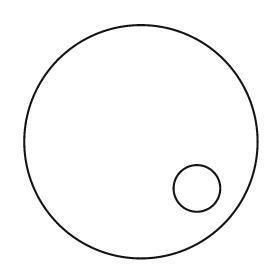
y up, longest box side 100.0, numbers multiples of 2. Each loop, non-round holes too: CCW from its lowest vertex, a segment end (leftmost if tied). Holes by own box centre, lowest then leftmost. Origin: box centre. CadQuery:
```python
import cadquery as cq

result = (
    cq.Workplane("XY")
    .moveTo(0.0, 0.0)
    .circle(50.0)
    .moveTo(24.0, -20.0)
    .circle(10.0)
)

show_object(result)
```